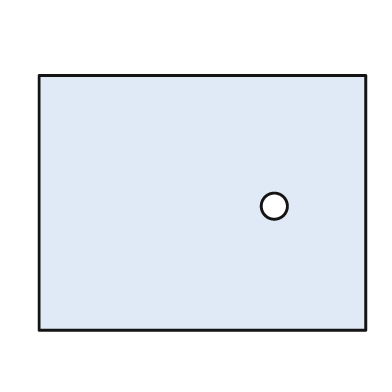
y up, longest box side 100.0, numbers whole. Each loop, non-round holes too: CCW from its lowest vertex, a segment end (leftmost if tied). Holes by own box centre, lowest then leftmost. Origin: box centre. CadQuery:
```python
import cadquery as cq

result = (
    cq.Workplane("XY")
    .moveTo(-50.0, -39.0)
    .lineTo(50.0, -39.0)
    .lineTo(50.0, 39.0)
    .lineTo(-50.0, 39.0)
    .close()
    .moveTo(22.0, -1.0)
    .circle(4.0)
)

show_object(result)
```